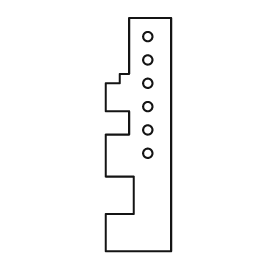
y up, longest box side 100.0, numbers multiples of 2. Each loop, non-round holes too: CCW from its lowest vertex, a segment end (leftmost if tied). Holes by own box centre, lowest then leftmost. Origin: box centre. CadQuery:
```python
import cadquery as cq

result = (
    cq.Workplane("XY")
    .moveTo(-14.0, -50.0)
    .lineTo(14.0, -50.0)
    .lineTo(14.0, 50.0)
    .lineTo(-4.0, 50.0)
    .lineTo(-4.0, 26.0)
    .lineTo(-8.0, 26.0)
    .lineTo(-8.0, 22.0)
    .lineTo(-14.0, 22.0)
    .lineTo(-14.0, 10.0)
    .lineTo(-4.0, 10.0)
    .lineTo(-4.0, 0.0)
    .lineTo(-14.0, 0.0)
    .lineTo(-14.0, -18.0)
    .lineTo(-2.0, -18.0)
    .lineTo(-2.0, -34.0)
    .lineTo(-14.0, -34.0)
    .close()
    .moveTo(4.0, -8.0)
    .circle(2.0)
    .moveTo(4.0, 2.0)
    .circle(2.0)
    .moveTo(4.0, 12.0)
    .circle(2.0)
    .moveTo(4.0, 22.0)
    .circle(2.0)
    .moveTo(4.0, 32.0)
    .circle(2.0)
    .moveTo(4.0, 42.0)
    .circle(2.0)
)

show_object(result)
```